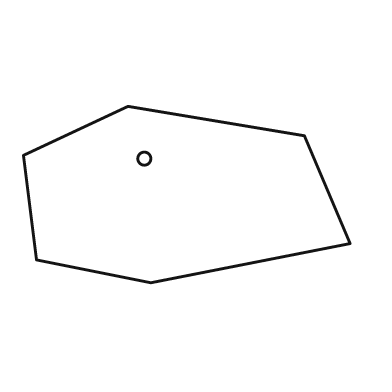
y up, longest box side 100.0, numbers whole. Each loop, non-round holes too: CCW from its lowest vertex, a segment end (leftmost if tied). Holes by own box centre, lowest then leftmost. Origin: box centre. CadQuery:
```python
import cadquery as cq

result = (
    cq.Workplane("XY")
    .moveTo(-11.0, -27.0)
    .lineTo(50.0, -15.0)
    .lineTo(36.0, 18.0)
    .lineTo(-18.0, 27.0)
    .lineTo(-50.0, 12.0)
    .lineTo(-46.0, -20.0)
    .close()
    .moveTo(-13.0, 11.0)
    .circle(2.0)
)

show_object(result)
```